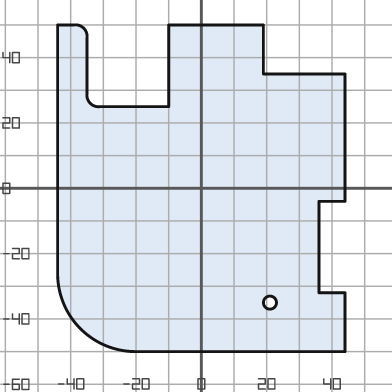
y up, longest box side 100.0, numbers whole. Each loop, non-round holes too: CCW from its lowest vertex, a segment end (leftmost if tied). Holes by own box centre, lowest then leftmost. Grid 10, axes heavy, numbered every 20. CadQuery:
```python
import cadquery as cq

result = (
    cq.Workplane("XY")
    .moveTo(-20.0, -50.0)
    .lineTo(44.0, -50.0)
    .lineTo(44.0, -32.0)
    .lineTo(36.0, -32.0)
    .lineTo(36.0, -4.0)
    .lineTo(44.0, -4.0)
    .lineTo(44.0, 35.0)
    .lineTo(19.0, 35.0)
    .lineTo(19.0, 50.0)
    .lineTo(-10.0, 50.0)
    .lineTo(-10.0, 25.0)
    .lineTo(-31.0, 25.0)
    .threePointArc((-34.0, 26.0), (-35.0, 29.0))
    .lineTo(-35.0, 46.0)
    .threePointArc((-36.0, 49.0), (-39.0, 50.0))
    .lineTo(-44.0, 50.0)
    .lineTo(-44.0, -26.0)
    .threePointArc((-37.0, -43.0), (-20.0, -50.0))
    .close()
    .moveTo(21.0, -35.0)
    .circle(2.0)
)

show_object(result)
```